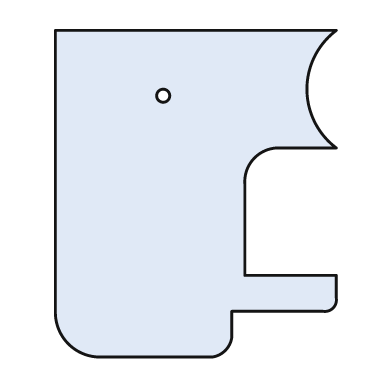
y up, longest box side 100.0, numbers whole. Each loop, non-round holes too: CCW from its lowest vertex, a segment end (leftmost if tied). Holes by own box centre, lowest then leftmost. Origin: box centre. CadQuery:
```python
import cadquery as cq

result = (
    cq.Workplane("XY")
    .moveTo(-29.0, -50.0)
    .lineTo(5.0, -50.0)
    .threePointArc((9.0, -48.0), (11.0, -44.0))
    .lineTo(11.0, -36.0)
    .lineTo(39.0, -36.0)
    .threePointArc((42.0, -35.0), (43.0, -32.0))
    .lineTo(43.0, -25.0)
    .lineTo(15.0, -25.0)
    .lineTo(15.0, 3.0)
    .threePointArc((18.0, 11.0), (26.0, 14.0))
    .lineTo(43.0, 14.0)
    .threePointArc((34.0, 32.0), (43.0, 50.0))
    .lineTo(-43.0, 50.0)
    .lineTo(-43.0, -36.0)
    .threePointArc((-39.0, -46.0), (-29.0, -50.0))
    .close()
    .moveTo(-10.0, 30.0)
    .circle(2.0)
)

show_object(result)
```